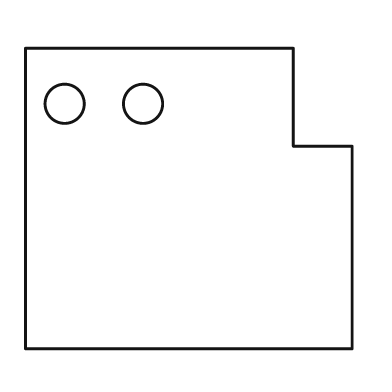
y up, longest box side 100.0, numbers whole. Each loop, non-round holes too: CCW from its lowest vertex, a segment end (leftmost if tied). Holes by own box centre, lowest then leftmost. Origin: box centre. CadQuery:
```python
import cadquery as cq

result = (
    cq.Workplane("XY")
    .moveTo(-50.0, -46.0)
    .lineTo(50.0, -46.0)
    .lineTo(50.0, 16.0)
    .lineTo(32.0, 16.0)
    .lineTo(32.0, 46.0)
    .lineTo(-50.0, 46.0)
    .close()
    .moveTo(-38.0, 29.0)
    .circle(6.0)
    .moveTo(-14.0, 29.0)
    .circle(6.0)
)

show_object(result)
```